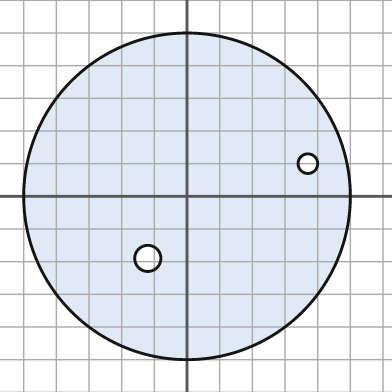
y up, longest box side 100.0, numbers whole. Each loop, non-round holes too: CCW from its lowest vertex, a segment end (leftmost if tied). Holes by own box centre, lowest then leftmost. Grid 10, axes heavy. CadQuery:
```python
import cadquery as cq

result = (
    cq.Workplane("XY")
    .moveTo(0.0, 0.0)
    .circle(50.0)
    .moveTo(-12.0, -19.0)
    .circle(4.0)
    .moveTo(37.0, 10.0)
    .circle(3.0)
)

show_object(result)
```